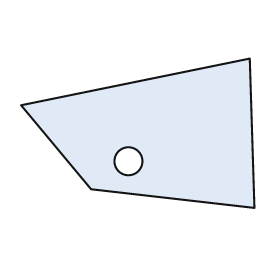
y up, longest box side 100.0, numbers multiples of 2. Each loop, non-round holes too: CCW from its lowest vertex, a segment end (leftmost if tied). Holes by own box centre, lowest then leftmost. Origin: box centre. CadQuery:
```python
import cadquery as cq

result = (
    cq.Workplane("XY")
    .moveTo(50.0, -32.0)
    .lineTo(48.0, 32.0)
    .lineTo(-50.0, 12.0)
    .lineTo(-20.0, -24.0)
    .close()
    .moveTo(-4.0, -12.0)
    .circle(6.0)
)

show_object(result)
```